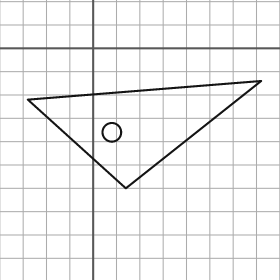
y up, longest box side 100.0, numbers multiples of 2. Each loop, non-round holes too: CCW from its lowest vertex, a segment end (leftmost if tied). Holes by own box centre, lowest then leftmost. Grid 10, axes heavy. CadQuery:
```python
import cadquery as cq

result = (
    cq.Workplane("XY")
    .moveTo(14.0, -60.0)
    .lineTo(72.0, -14.0)
    .lineTo(-28.0, -22.0)
    .close()
    .moveTo(8.0, -36.0)
    .circle(4.0)
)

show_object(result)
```